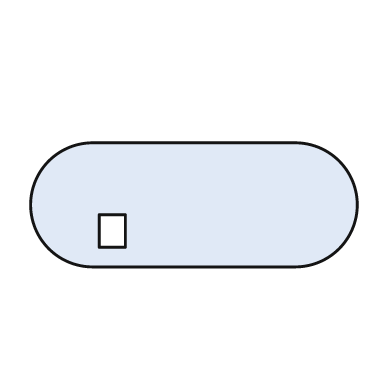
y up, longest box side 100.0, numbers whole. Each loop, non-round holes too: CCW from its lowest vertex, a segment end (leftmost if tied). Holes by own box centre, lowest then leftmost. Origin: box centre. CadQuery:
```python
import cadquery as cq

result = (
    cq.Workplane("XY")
    .moveTo(-31.0, -19.0)
    .lineTo(31.0, -19.0)
    .threePointArc((50.0, 0.0), (31.0, 19.0))
    .lineTo(-31.0, 19.0)
    .threePointArc((-50.0, 0.0), (-31.0, -19.0))
    .close()
    .moveTo(-29.0, -13.0)
    .lineTo(-21.0, -13.0)
    .lineTo(-21.0, -3.0)
    .lineTo(-29.0, -3.0)
    .close()
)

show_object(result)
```